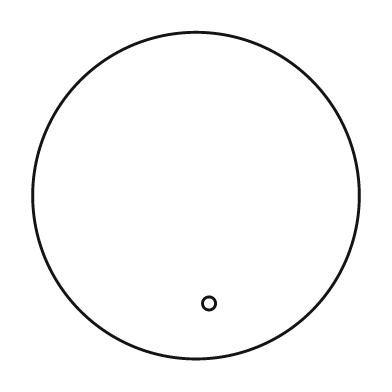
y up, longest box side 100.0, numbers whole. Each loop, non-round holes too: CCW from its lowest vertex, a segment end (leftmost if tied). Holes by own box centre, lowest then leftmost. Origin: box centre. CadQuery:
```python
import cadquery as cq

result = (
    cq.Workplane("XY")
    .moveTo(0.0, 0.0)
    .circle(50.0)
    .moveTo(4.0, -33.0)
    .circle(2.0)
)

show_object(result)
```